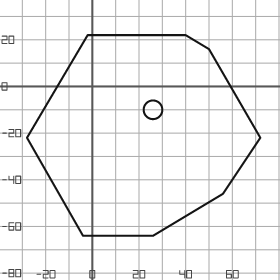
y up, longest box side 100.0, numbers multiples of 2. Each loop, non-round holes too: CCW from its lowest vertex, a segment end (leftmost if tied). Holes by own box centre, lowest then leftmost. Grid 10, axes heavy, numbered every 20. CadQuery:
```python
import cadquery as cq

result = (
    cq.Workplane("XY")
    .moveTo(-4.0, -64.0)
    .lineTo(26.0, -64.0)
    .lineTo(56.0, -46.0)
    .lineTo(72.0, -22.0)
    .lineTo(50.0, 16.0)
    .lineTo(40.0, 22.0)
    .lineTo(-2.0, 22.0)
    .lineTo(-28.0, -22.0)
    .close()
    .moveTo(26.0, -10.0)
    .circle(4.0)
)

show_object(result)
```